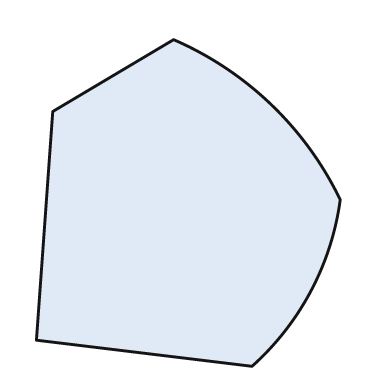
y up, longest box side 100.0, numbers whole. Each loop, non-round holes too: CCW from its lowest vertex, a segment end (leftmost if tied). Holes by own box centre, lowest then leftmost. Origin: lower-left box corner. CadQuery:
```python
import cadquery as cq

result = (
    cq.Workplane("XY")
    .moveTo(66.0, 0.0)
    .threePointArc((84.0, 23.0), (93.0, 51.0))
    .threePointArc((72.0, 80.0), (42.0, 100.0))
    .lineTo(5.0, 78.0)
    .lineTo(0.0, 8.0)
    .close()
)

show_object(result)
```